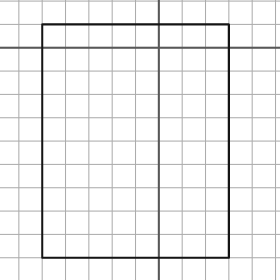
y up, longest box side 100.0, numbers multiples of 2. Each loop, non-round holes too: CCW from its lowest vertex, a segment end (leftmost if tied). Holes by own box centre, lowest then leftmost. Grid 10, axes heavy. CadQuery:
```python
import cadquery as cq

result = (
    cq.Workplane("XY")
    .moveTo(-50.0, -90.0)
    .lineTo(30.0, -90.0)
    .lineTo(30.0, 10.0)
    .lineTo(-50.0, 10.0)
    .close()
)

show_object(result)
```